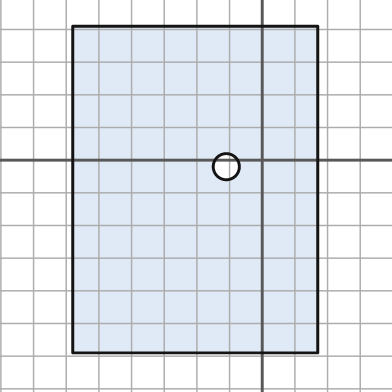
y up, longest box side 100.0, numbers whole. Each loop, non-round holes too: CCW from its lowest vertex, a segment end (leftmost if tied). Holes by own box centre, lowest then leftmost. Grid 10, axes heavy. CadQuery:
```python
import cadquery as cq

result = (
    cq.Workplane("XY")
    .moveTo(-58.0, -59.0)
    .lineTo(17.0, -59.0)
    .lineTo(17.0, 41.0)
    .lineTo(-58.0, 41.0)
    .close()
    .moveTo(-11.0, -2.0)
    .circle(4.0)
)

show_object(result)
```